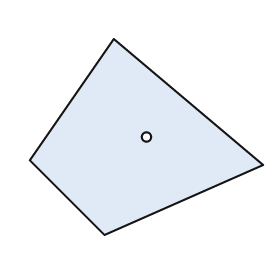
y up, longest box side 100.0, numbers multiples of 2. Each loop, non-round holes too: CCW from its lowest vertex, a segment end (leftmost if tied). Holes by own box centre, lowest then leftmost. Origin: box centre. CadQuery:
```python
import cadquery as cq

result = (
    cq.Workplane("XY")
    .moveTo(-18.0, -42.0)
    .lineTo(50.0, -12.0)
    .lineTo(-14.0, 42.0)
    .lineTo(-50.0, -10.0)
    .close()
    .moveTo(0.0, 0.0)
    .circle(2.0)
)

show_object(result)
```